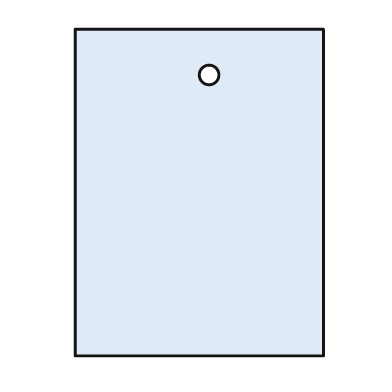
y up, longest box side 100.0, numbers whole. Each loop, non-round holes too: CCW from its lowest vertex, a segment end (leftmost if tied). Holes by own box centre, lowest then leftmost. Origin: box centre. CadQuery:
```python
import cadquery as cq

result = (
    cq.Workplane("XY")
    .moveTo(-38.0, -50.0)
    .lineTo(38.0, -50.0)
    .lineTo(38.0, 50.0)
    .lineTo(-38.0, 50.0)
    .close()
    .moveTo(3.0, 36.0)
    .circle(3.0)
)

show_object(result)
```